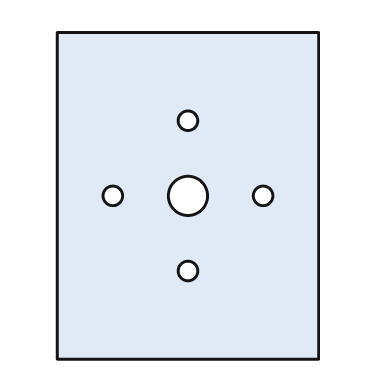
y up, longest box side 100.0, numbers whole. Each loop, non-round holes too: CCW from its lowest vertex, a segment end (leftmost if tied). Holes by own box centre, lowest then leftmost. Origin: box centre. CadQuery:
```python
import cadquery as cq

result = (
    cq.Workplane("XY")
    .moveTo(-40.0, -50.0)
    .lineTo(40.0, -50.0)
    .lineTo(40.0, 50.0)
    .lineTo(-40.0, 50.0)
    .close()
    .moveTo(0.0, -23.0)
    .circle(3.0)
    .moveTo(-23.0, 0.0)
    .circle(3.0)
    .moveTo(0.0, 0.0)
    .circle(6.0)
    .moveTo(23.0, 0.0)
    .circle(3.0)
    .moveTo(0.0, 23.0)
    .circle(3.0)
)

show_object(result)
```